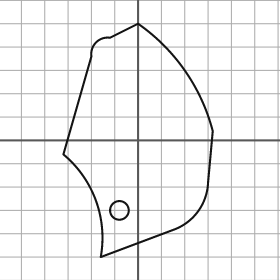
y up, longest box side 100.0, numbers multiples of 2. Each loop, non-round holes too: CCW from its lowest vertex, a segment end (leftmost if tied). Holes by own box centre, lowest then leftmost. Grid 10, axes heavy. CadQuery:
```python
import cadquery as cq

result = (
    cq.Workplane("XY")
    .moveTo(-16.0, -50.0)
    .lineTo(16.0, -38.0)
    .threePointArc((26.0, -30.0), (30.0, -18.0))
    .lineTo(32.0, 4.0)
    .threePointArc((20.0, 30.0), (0.0, 50.0))
    .lineTo(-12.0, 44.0)
    .threePointArc((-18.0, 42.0), (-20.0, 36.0))
    .lineTo(-32.0, -6.0)
    .threePointArc((-18.0, -26.0), (-16.0, -50.0))
    .close()
    .moveTo(-8.0, -30.0)
    .circle(4.0)
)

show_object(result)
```